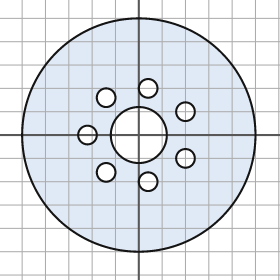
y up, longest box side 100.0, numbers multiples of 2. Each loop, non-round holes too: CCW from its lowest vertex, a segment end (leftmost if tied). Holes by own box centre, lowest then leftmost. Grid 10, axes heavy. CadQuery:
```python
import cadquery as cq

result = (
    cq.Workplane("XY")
    .moveTo(0.0, 0.0)
    .circle(50.0)
    .moveTo(4.0, -20.0)
    .circle(4.0)
    .moveTo(-14.0, -16.0)
    .circle(4.0)
    .moveTo(20.0, -10.0)
    .circle(4.0)
    .moveTo(-22.0, 0.0)
    .circle(4.0)
    .moveTo(0.0, 0.0)
    .circle(12.0)
    .moveTo(20.0, 10.0)
    .circle(4.0)
    .moveTo(-14.0, 16.0)
    .circle(4.0)
    .moveTo(4.0, 20.0)
    .circle(4.0)
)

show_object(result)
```